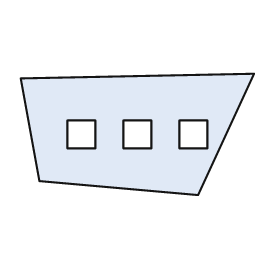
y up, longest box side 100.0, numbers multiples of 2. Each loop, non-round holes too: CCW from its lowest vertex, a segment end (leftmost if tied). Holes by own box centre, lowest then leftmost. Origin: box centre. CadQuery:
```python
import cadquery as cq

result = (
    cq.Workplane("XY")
    .moveTo(26.0, -26.0)
    .lineTo(50.0, 26.0)
    .lineTo(-50.0, 24.0)
    .lineTo(-42.0, -20.0)
    .close()
    .moveTo(-30.0, -6.0)
    .lineTo(-18.0, -6.0)
    .lineTo(-18.0, 6.0)
    .lineTo(-30.0, 6.0)
    .close()
    .moveTo(-6.0, -6.0)
    .lineTo(6.0, -6.0)
    .lineTo(6.0, 6.0)
    .lineTo(-6.0, 6.0)
    .close()
    .moveTo(18.0, -6.0)
    .lineTo(30.0, -6.0)
    .lineTo(30.0, 6.0)
    .lineTo(18.0, 6.0)
    .close()
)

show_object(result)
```